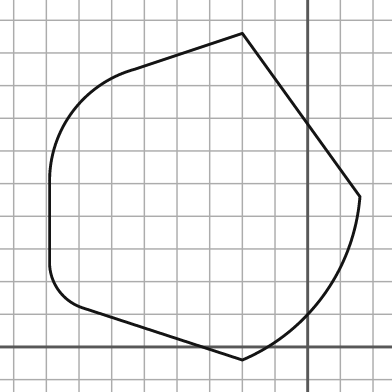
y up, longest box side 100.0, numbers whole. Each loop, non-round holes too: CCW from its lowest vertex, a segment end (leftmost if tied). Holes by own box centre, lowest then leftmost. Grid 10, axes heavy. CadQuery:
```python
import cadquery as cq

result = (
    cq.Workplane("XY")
    .moveTo(-20.0, -4.0)
    .threePointArc((5.0, 16.0), (16.0, 46.0))
    .lineTo(-20.0, 96.0)
    .lineTo(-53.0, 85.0)
    .threePointArc((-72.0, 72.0), (-79.0, 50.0))
    .lineTo(-79.0, 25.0)
    .threePointArc((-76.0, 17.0), (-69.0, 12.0))
    .close()
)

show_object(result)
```